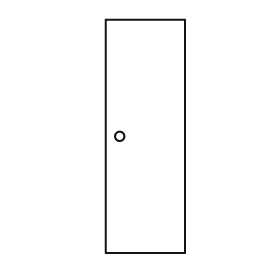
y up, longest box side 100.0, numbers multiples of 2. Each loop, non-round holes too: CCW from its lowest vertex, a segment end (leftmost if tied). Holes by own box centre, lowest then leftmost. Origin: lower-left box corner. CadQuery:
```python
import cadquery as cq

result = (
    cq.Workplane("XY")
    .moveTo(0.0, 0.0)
    .lineTo(34.0, 0.0)
    .lineTo(34.0, 100.0)
    .lineTo(0.0, 100.0)
    .close()
    .moveTo(6.0, 50.0)
    .circle(2.0)
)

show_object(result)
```